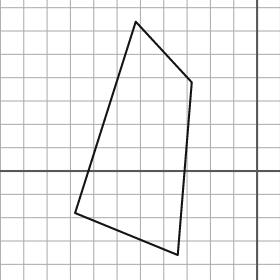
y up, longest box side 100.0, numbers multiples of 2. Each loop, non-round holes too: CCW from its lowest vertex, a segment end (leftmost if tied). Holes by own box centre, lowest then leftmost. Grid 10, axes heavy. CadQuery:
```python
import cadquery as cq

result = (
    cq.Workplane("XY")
    .moveTo(-34.0, -36.0)
    .lineTo(-28.0, 38.0)
    .lineTo(-52.0, 64.0)
    .lineTo(-78.0, -18.0)
    .close()
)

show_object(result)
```